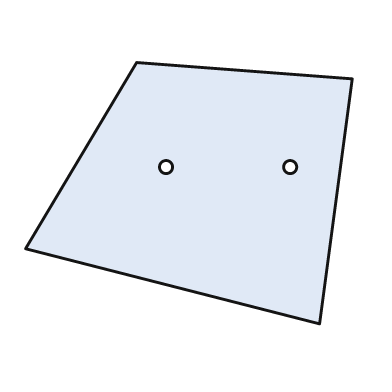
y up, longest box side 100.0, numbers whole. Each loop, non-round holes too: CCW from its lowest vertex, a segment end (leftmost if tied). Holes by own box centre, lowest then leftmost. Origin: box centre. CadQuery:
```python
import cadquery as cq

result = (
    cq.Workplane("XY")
    .moveTo(40.0, -40.0)
    .lineTo(50.0, 35.0)
    .lineTo(-16.0, 40.0)
    .lineTo(-50.0, -17.0)
    .close()
    .moveTo(-7.0, 8.0)
    .circle(2.0)
    .moveTo(31.0, 8.0)
    .circle(2.0)
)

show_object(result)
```